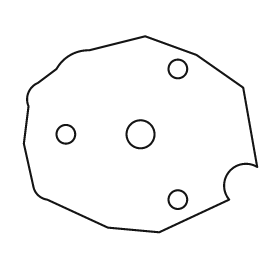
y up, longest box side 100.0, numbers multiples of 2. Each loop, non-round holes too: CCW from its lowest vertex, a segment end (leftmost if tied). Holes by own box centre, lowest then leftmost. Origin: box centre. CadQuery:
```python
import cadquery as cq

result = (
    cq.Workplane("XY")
    .moveTo(8.0, -42.0)
    .lineTo(38.0, -28.0)
    .threePointArc((38.0, -16.0), (50.0, -14.0))
    .lineTo(44.0, 20.0)
    .lineTo(24.0, 34.0)
    .lineTo(2.0, 42.0)
    .lineTo(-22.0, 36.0)
    .threePointArc((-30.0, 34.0), (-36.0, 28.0))
    .lineTo(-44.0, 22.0)
    .threePointArc((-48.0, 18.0), (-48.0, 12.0))
    .lineTo(-50.0, -4.0)
    .lineTo(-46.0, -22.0)
    .threePointArc((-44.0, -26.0), (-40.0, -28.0))
    .lineTo(-14.0, -40.0)
    .close()
    .moveTo(16.0, -28.0)
    .circle(4.0)
    .moveTo(-32.0, 0.0)
    .circle(4.0)
    .moveTo(0.0, 0.0)
    .circle(6.0)
    .moveTo(16.0, 28.0)
    .circle(4.0)
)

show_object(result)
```